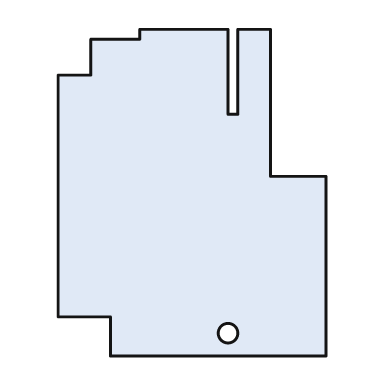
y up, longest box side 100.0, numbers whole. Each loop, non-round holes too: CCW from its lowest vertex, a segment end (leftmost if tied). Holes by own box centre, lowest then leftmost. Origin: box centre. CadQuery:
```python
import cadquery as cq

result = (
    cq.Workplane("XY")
    .moveTo(-25.0, -50.0)
    .lineTo(41.0, -50.0)
    .lineTo(41.0, 5.0)
    .lineTo(24.0, 5.0)
    .lineTo(24.0, 50.0)
    .lineTo(14.0, 50.0)
    .lineTo(14.0, 24.0)
    .lineTo(11.0, 24.0)
    .lineTo(11.0, 50.0)
    .lineTo(-16.0, 50.0)
    .lineTo(-16.0, 47.0)
    .lineTo(-31.0, 47.0)
    .lineTo(-31.0, 36.0)
    .lineTo(-41.0, 36.0)
    .lineTo(-41.0, -38.0)
    .lineTo(-25.0, -38.0)
    .close()
    .moveTo(11.0, -43.0)
    .circle(3.0)
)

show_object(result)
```